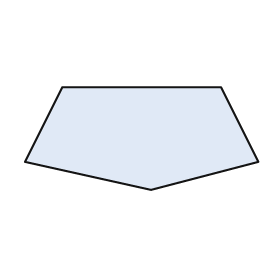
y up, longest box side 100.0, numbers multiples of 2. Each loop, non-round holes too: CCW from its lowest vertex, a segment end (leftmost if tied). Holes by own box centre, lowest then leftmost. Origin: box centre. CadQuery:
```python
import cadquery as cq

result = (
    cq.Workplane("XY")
    .moveTo(4.0, -22.0)
    .lineTo(50.0, -10.0)
    .lineTo(34.0, 22.0)
    .lineTo(-34.0, 22.0)
    .lineTo(-50.0, -10.0)
    .close()
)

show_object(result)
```